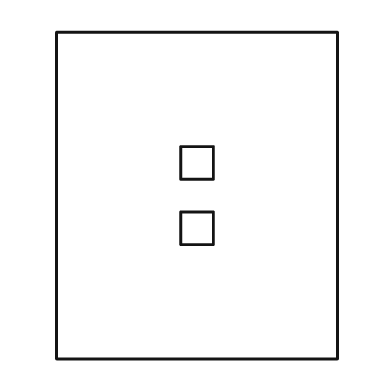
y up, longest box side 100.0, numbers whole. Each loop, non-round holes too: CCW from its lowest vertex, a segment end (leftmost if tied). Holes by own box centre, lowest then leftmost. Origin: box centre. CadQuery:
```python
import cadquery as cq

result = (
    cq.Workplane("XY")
    .moveTo(-43.0, -50.0)
    .lineTo(43.0, -50.0)
    .lineTo(43.0, 50.0)
    .lineTo(-43.0, 50.0)
    .close()
    .moveTo(-5.0, -15.0)
    .lineTo(5.0, -15.0)
    .lineTo(5.0, -5.0)
    .lineTo(-5.0, -5.0)
    .close()
    .moveTo(-5.0, 5.0)
    .lineTo(5.0, 5.0)
    .lineTo(5.0, 15.0)
    .lineTo(-5.0, 15.0)
    .close()
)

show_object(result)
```